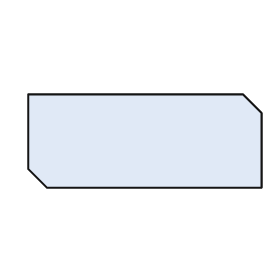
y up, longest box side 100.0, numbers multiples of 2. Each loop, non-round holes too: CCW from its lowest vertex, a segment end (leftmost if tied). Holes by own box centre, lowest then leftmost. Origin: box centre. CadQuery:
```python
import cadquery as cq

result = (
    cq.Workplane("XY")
    .moveTo(-42.0, -20.0)
    .lineTo(50.0, -20.0)
    .lineTo(50.0, 12.0)
    .lineTo(42.0, 20.0)
    .lineTo(-50.0, 20.0)
    .lineTo(-50.0, -12.0)
    .close()
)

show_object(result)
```